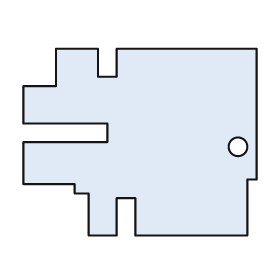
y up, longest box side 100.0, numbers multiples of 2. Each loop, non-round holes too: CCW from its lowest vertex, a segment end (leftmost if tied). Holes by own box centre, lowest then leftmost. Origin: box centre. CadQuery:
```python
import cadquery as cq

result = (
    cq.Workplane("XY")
    .moveTo(-22.0, -40.0)
    .lineTo(-10.0, -40.0)
    .lineTo(-10.0, -24.0)
    .lineTo(-2.0, -24.0)
    .lineTo(-2.0, -40.0)
    .lineTo(46.0, -40.0)
    .lineTo(46.0, -16.0)
    .lineTo(50.0, -16.0)
    .lineTo(50.0, 40.0)
    .lineTo(-10.0, 40.0)
    .lineTo(-10.0, 28.0)
    .lineTo(-18.0, 28.0)
    .lineTo(-18.0, 40.0)
    .lineTo(-36.0, 40.0)
    .lineTo(-36.0, 24.0)
    .lineTo(-50.0, 24.0)
    .lineTo(-50.0, 8.0)
    .lineTo(-14.0, 8.0)
    .lineTo(-14.0, 0.0)
    .lineTo(-50.0, 0.0)
    .lineTo(-50.0, -18.0)
    .lineTo(-28.0, -18.0)
    .lineTo(-28.0, -22.0)
    .lineTo(-22.0, -22.0)
    .close()
    .moveTo(42.0, -2.0)
    .circle(4.0)
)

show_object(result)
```